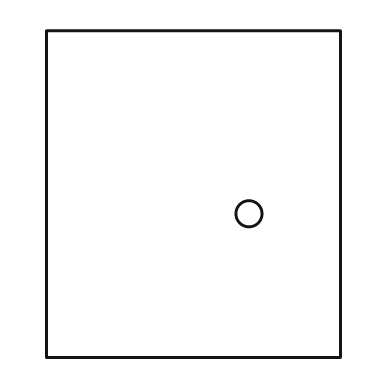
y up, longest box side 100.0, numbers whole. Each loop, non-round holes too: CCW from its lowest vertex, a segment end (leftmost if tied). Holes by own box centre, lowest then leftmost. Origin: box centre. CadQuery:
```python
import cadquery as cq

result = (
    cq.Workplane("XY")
    .moveTo(-45.0, -50.0)
    .lineTo(45.0, -50.0)
    .lineTo(45.0, 50.0)
    .lineTo(-45.0, 50.0)
    .close()
    .moveTo(17.0, -6.0)
    .circle(4.0)
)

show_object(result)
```